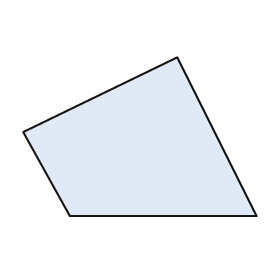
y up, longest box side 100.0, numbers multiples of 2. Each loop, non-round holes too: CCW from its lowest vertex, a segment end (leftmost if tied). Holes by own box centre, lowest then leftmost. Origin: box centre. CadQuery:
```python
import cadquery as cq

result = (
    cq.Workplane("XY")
    .moveTo(-30.0, -34.0)
    .lineTo(50.0, -34.0)
    .lineTo(16.0, 34.0)
    .lineTo(-50.0, 2.0)
    .close()
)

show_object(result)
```